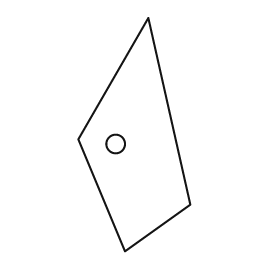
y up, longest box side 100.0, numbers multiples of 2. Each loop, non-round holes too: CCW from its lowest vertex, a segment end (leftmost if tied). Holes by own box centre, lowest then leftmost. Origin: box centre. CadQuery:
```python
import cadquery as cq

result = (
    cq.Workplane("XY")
    .moveTo(-4.0, -50.0)
    .lineTo(24.0, -30.0)
    .lineTo(6.0, 50.0)
    .lineTo(-24.0, -2.0)
    .close()
    .moveTo(-8.0, -4.0)
    .circle(4.0)
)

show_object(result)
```